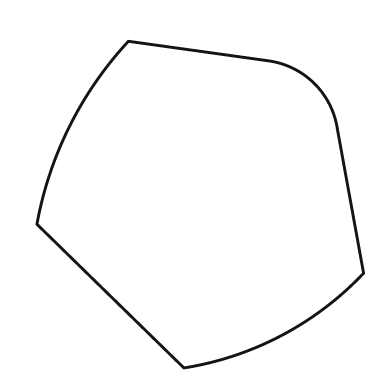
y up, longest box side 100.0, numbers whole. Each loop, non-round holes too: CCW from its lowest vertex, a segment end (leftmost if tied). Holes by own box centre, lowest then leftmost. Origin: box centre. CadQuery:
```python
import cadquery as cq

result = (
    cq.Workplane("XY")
    .moveTo(-5.0, -50.0)
    .threePointArc((25.0, -40.0), (50.0, -21.0))
    .lineTo(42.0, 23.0)
    .threePointArc((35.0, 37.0), (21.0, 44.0))
    .lineTo(-22.0, 50.0)
    .threePointArc((-40.0, 24.0), (-50.0, -6.0))
    .close()
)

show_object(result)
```